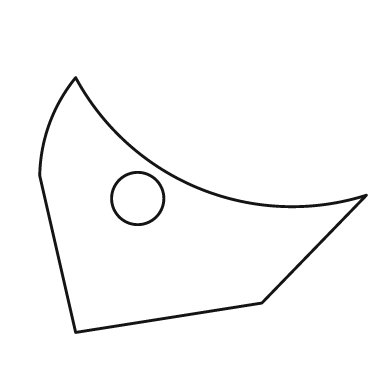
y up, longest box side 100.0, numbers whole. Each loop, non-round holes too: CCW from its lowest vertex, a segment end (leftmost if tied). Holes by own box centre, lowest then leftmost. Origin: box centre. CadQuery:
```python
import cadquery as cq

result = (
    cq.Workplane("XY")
    .moveTo(-39.0, -39.0)
    .lineTo(18.0, -30.0)
    .lineTo(50.0, 3.0)
    .threePointArc((-1.0, 5.0), (-39.0, 39.0))
    .threePointArc((-47.0, 25.0), (-50.0, 9.0))
    .close()
    .moveTo(-20.0, 2.0)
    .circle(8.0)
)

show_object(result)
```